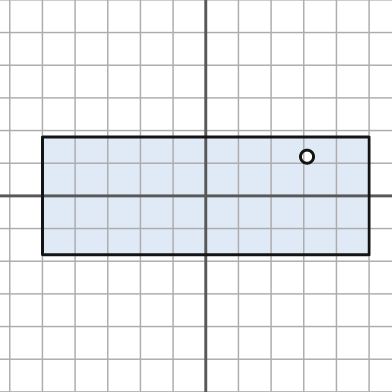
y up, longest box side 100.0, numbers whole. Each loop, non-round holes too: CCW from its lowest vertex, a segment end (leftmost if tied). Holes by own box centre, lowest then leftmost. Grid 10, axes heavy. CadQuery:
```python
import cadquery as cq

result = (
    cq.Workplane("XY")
    .moveTo(-50.0, -18.0)
    .lineTo(50.0, -18.0)
    .lineTo(50.0, 18.0)
    .lineTo(-50.0, 18.0)
    .close()
    .moveTo(31.0, 12.0)
    .circle(2.0)
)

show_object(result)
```